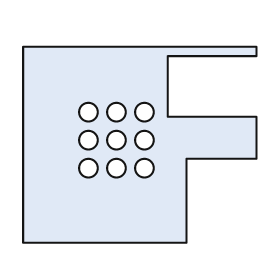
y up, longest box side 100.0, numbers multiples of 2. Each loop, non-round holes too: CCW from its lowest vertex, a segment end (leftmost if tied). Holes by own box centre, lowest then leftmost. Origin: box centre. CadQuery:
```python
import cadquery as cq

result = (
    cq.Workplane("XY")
    .moveTo(-50.0, -42.0)
    .lineTo(20.0, -42.0)
    .lineTo(20.0, -6.0)
    .lineTo(50.0, -6.0)
    .lineTo(50.0, 12.0)
    .lineTo(12.0, 12.0)
    .lineTo(12.0, 38.0)
    .lineTo(50.0, 38.0)
    .lineTo(50.0, 42.0)
    .lineTo(-50.0, 42.0)
    .close()
    .moveTo(-22.0, -10.0)
    .circle(4.0)
    .moveTo(-10.0, -10.0)
    .circle(4.0)
    .moveTo(2.0, -10.0)
    .circle(4.0)
    .moveTo(-22.0, 2.0)
    .circle(4.0)
    .moveTo(-10.0, 2.0)
    .circle(4.0)
    .moveTo(2.0, 2.0)
    .circle(4.0)
    .moveTo(-22.0, 14.0)
    .circle(4.0)
    .moveTo(-10.0, 14.0)
    .circle(4.0)
    .moveTo(2.0, 14.0)
    .circle(4.0)
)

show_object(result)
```